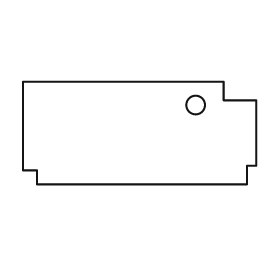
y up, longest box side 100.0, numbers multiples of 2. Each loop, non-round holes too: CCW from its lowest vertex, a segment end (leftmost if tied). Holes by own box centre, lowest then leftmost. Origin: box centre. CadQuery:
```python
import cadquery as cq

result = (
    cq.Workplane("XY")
    .moveTo(-44.0, -22.0)
    .lineTo(46.0, -22.0)
    .lineTo(46.0, -14.0)
    .lineTo(50.0, -14.0)
    .lineTo(50.0, 14.0)
    .lineTo(36.0, 14.0)
    .lineTo(36.0, 22.0)
    .lineTo(-50.0, 22.0)
    .lineTo(-50.0, -16.0)
    .lineTo(-44.0, -16.0)
    .close()
    .moveTo(24.0, 12.0)
    .circle(4.0)
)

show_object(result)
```